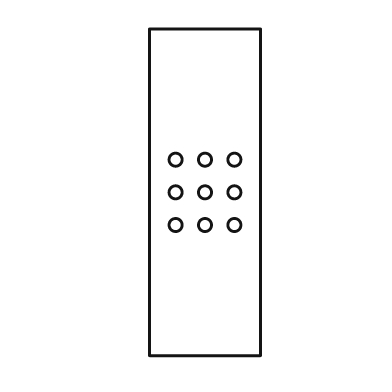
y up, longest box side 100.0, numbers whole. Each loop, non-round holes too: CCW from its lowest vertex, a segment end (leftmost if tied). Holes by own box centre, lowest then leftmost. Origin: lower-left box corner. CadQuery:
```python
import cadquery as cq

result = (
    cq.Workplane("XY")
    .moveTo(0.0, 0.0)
    .lineTo(34.0, 0.0)
    .lineTo(34.0, 100.0)
    .lineTo(0.0, 100.0)
    .close()
    .moveTo(8.0, 40.0)
    .circle(2.0)
    .moveTo(17.0, 40.0)
    .circle(2.0)
    .moveTo(26.0, 40.0)
    .circle(2.0)
    .moveTo(8.0, 50.0)
    .circle(2.0)
    .moveTo(17.0, 50.0)
    .circle(2.0)
    .moveTo(26.0, 50.0)
    .circle(2.0)
    .moveTo(8.0, 60.0)
    .circle(2.0)
    .moveTo(17.0, 60.0)
    .circle(2.0)
    .moveTo(26.0, 60.0)
    .circle(2.0)
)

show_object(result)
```